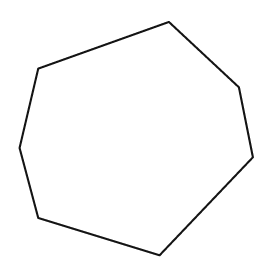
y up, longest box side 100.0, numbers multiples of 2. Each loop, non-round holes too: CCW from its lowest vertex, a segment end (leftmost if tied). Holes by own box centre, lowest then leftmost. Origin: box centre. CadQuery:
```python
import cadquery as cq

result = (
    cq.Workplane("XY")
    .moveTo(10.0, -50.0)
    .lineTo(50.0, -8.0)
    .lineTo(44.0, 22.0)
    .lineTo(14.0, 50.0)
    .lineTo(-42.0, 30.0)
    .lineTo(-50.0, -4.0)
    .lineTo(-42.0, -34.0)
    .close()
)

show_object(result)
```